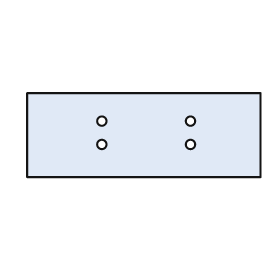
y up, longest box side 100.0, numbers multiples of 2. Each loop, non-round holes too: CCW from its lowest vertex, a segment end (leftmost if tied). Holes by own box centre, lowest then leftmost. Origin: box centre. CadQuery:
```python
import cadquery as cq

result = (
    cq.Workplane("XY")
    .moveTo(-50.0, -18.0)
    .lineTo(50.0, -18.0)
    .lineTo(50.0, 18.0)
    .lineTo(-50.0, 18.0)
    .close()
    .moveTo(-18.0, -4.0)
    .circle(2.0)
    .moveTo(20.0, -4.0)
    .circle(2.0)
    .moveTo(-18.0, 6.0)
    .circle(2.0)
    .moveTo(20.0, 6.0)
    .circle(2.0)
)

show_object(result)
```